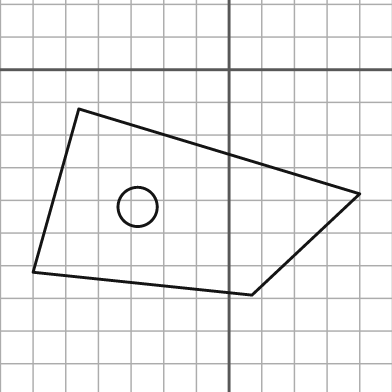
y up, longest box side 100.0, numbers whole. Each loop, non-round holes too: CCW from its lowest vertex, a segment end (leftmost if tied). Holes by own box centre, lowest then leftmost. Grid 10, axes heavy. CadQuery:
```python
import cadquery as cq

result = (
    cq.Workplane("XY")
    .moveTo(7.0, -69.0)
    .lineTo(40.0, -38.0)
    .lineTo(-46.0, -12.0)
    .lineTo(-60.0, -62.0)
    .close()
    .moveTo(-28.0, -42.0)
    .circle(6.0)
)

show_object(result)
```